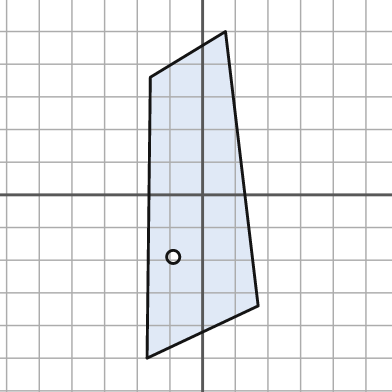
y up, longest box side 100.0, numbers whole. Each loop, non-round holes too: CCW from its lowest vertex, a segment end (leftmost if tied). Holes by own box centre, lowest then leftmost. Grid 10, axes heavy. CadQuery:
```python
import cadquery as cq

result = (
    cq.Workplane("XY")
    .moveTo(-17.0, -50.0)
    .lineTo(17.0, -34.0)
    .lineTo(7.0, 50.0)
    .lineTo(-16.0, 36.0)
    .close()
    .moveTo(-9.0, -19.0)
    .circle(2.0)
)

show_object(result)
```